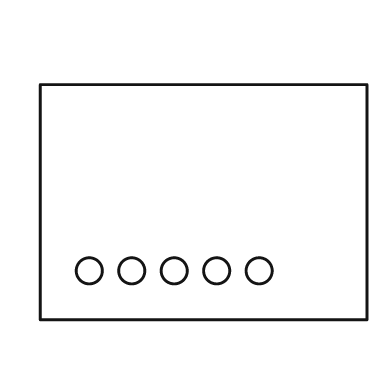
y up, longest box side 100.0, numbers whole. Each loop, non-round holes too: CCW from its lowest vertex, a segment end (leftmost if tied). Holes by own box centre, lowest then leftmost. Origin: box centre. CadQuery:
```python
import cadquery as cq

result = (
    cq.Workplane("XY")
    .moveTo(-50.0, -36.0)
    .lineTo(50.0, -36.0)
    .lineTo(50.0, 36.0)
    .lineTo(-50.0, 36.0)
    .close()
    .moveTo(-35.0, -21.0)
    .circle(4.0)
    .moveTo(-22.0, -21.0)
    .circle(4.0)
    .moveTo(-9.0, -21.0)
    .circle(4.0)
    .moveTo(4.0, -21.0)
    .circle(4.0)
    .moveTo(17.0, -21.0)
    .circle(4.0)
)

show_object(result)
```